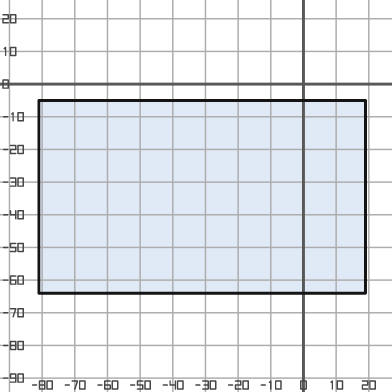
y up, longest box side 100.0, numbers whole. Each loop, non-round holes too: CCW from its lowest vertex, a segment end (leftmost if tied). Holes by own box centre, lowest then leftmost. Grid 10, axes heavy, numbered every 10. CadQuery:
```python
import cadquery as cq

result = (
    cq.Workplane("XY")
    .moveTo(-81.0, -64.0)
    .lineTo(19.0, -64.0)
    .lineTo(19.0, -5.0)
    .lineTo(-81.0, -5.0)
    .close()
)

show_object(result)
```